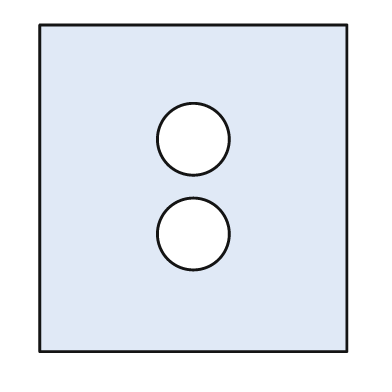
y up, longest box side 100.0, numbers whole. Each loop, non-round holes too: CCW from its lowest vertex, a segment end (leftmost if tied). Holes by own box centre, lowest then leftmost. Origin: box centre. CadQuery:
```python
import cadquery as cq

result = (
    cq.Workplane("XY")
    .moveTo(-47.0, -50.0)
    .lineTo(47.0, -50.0)
    .lineTo(47.0, 50.0)
    .lineTo(-47.0, 50.0)
    .close()
    .moveTo(0.0, -14.0)
    .circle(11.0)
    .moveTo(0.0, 15.0)
    .circle(11.0)
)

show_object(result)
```